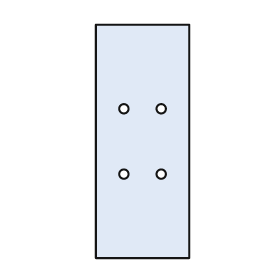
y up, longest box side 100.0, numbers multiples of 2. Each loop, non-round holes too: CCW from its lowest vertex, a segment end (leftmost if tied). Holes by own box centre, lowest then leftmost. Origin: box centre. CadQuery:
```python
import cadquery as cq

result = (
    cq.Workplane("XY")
    .moveTo(-20.0, -50.0)
    .lineTo(20.0, -50.0)
    .lineTo(20.0, 50.0)
    .lineTo(-20.0, 50.0)
    .close()
    .moveTo(-8.0, -14.0)
    .circle(2.0)
    .moveTo(8.0, -14.0)
    .circle(2.0)
    .moveTo(-8.0, 14.0)
    .circle(2.0)
    .moveTo(8.0, 14.0)
    .circle(2.0)
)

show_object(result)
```